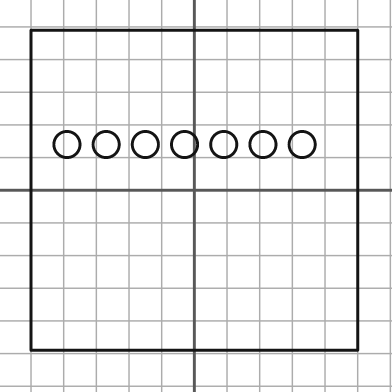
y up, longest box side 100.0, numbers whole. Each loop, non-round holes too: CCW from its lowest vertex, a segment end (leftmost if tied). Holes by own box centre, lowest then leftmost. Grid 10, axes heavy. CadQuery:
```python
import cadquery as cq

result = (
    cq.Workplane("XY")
    .moveTo(-50.0, -49.0)
    .lineTo(50.0, -49.0)
    .lineTo(50.0, 49.0)
    .lineTo(-50.0, 49.0)
    .close()
    .moveTo(-39.0, 14.0)
    .circle(4.0)
    .moveTo(-27.0, 14.0)
    .circle(4.0)
    .moveTo(-15.0, 14.0)
    .circle(4.0)
    .moveTo(-3.0, 14.0)
    .circle(4.0)
    .moveTo(9.0, 14.0)
    .circle(4.0)
    .moveTo(21.0, 14.0)
    .circle(4.0)
    .moveTo(33.0, 14.0)
    .circle(4.0)
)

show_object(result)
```